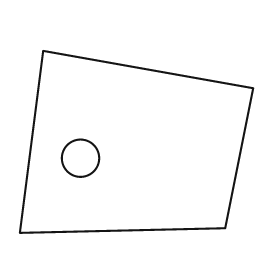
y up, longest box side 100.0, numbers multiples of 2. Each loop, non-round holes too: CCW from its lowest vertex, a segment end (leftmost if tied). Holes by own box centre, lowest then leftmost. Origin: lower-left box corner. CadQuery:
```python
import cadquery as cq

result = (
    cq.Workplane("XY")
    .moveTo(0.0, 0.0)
    .lineTo(88.0, 2.0)
    .lineTo(100.0, 62.0)
    .lineTo(10.0, 78.0)
    .close()
    .moveTo(26.0, 32.0)
    .circle(8.0)
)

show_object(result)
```